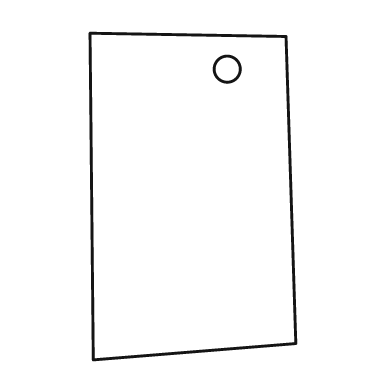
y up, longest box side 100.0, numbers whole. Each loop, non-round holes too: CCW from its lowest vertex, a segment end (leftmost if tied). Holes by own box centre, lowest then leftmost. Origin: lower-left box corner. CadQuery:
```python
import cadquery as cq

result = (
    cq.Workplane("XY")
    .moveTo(1.0, 0.0)
    .lineTo(63.0, 5.0)
    .lineTo(60.0, 99.0)
    .lineTo(0.0, 100.0)
    .close()
    .moveTo(42.0, 89.0)
    .circle(4.0)
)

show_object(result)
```